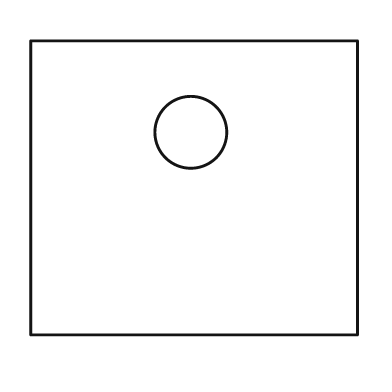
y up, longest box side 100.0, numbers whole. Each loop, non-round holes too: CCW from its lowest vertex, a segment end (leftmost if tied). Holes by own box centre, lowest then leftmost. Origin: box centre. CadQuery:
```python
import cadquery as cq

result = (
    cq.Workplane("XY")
    .moveTo(-50.0, -45.0)
    .lineTo(50.0, -45.0)
    .lineTo(50.0, 45.0)
    .lineTo(-50.0, 45.0)
    .close()
    .moveTo(-1.0, 17.0)
    .circle(11.0)
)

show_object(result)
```